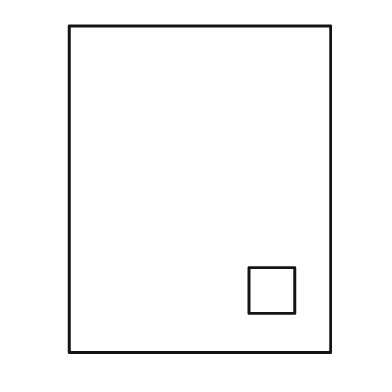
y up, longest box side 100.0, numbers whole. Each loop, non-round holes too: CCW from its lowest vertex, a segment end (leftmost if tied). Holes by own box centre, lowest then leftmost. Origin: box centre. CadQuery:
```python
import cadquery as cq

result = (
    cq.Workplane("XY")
    .moveTo(-40.0, -50.0)
    .lineTo(40.0, -50.0)
    .lineTo(40.0, 50.0)
    .lineTo(-40.0, 50.0)
    .close()
    .moveTo(15.0, -38.0)
    .lineTo(29.0, -38.0)
    .lineTo(29.0, -24.0)
    .lineTo(15.0, -24.0)
    .close()
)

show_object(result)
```